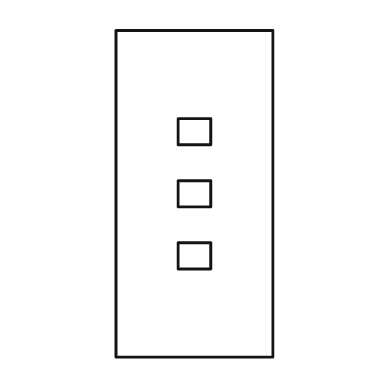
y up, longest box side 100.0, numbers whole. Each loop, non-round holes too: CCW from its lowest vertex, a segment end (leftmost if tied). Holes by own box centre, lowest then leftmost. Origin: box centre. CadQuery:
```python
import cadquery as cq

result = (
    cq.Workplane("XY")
    .moveTo(-24.0, -50.0)
    .lineTo(24.0, -50.0)
    .lineTo(24.0, 50.0)
    .lineTo(-24.0, 50.0)
    .close()
    .moveTo(-5.0, -23.0)
    .lineTo(5.0, -23.0)
    .lineTo(5.0, -15.0)
    .lineTo(-5.0, -15.0)
    .close()
    .moveTo(-5.0, -4.0)
    .lineTo(5.0, -4.0)
    .lineTo(5.0, 4.0)
    .lineTo(-5.0, 4.0)
    .close()
    .moveTo(-5.0, 15.0)
    .lineTo(5.0, 15.0)
    .lineTo(5.0, 23.0)
    .lineTo(-5.0, 23.0)
    .close()
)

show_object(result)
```